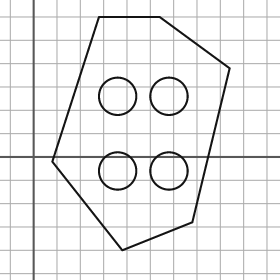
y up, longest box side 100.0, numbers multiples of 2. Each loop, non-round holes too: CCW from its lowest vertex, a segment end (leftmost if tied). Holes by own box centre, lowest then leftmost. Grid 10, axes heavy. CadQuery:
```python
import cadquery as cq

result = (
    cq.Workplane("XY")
    .moveTo(38.0, -40.0)
    .lineTo(68.0, -28.0)
    .lineTo(84.0, 38.0)
    .lineTo(54.0, 60.0)
    .lineTo(28.0, 60.0)
    .lineTo(8.0, -2.0)
    .close()
    .moveTo(36.0, -6.0)
    .circle(8.0)
    .moveTo(58.0, -6.0)
    .circle(8.0)
    .moveTo(36.0, 26.0)
    .circle(8.0)
    .moveTo(58.0, 26.0)
    .circle(8.0)
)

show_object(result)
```